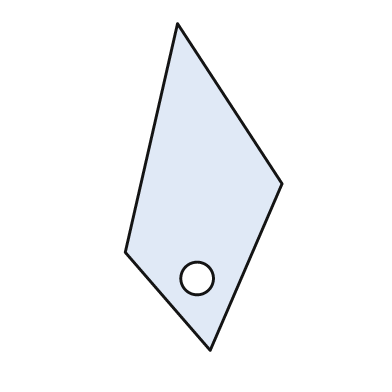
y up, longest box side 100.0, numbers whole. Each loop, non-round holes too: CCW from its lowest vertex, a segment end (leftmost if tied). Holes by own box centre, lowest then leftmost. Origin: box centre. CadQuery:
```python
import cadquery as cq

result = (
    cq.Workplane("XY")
    .moveTo(2.0, -50.0)
    .lineTo(24.0, 1.0)
    .lineTo(-8.0, 50.0)
    .lineTo(-24.0, -20.0)
    .close()
    .moveTo(-2.0, -28.0)
    .circle(5.0)
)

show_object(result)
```